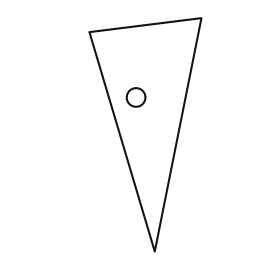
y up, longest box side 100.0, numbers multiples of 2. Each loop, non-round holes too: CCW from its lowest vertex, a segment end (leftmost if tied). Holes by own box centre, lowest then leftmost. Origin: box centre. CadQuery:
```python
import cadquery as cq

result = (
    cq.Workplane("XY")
    .moveTo(4.0, -50.0)
    .lineTo(24.0, 50.0)
    .lineTo(-24.0, 44.0)
    .close()
    .moveTo(-4.0, 16.0)
    .circle(4.0)
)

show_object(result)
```